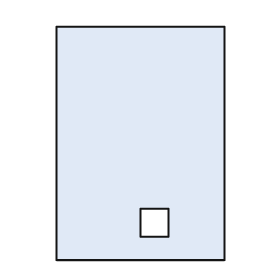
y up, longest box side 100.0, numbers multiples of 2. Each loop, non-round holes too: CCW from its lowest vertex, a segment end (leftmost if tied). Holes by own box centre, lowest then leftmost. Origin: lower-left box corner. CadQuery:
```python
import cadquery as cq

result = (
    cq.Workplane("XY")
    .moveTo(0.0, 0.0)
    .lineTo(72.0, 0.0)
    .lineTo(72.0, 100.0)
    .lineTo(0.0, 100.0)
    .close()
    .moveTo(36.0, 10.0)
    .lineTo(48.0, 10.0)
    .lineTo(48.0, 22.0)
    .lineTo(36.0, 22.0)
    .close()
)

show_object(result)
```